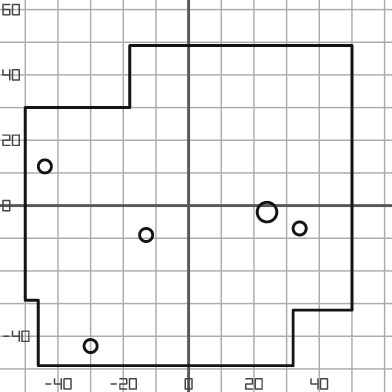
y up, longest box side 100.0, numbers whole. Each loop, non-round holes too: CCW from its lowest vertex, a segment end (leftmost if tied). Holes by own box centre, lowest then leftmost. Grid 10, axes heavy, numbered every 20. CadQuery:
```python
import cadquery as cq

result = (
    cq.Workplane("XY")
    .moveTo(-46.0, -49.0)
    .lineTo(32.0, -49.0)
    .lineTo(32.0, -32.0)
    .lineTo(50.0, -32.0)
    .lineTo(50.0, 49.0)
    .lineTo(-18.0, 49.0)
    .lineTo(-18.0, 30.0)
    .lineTo(-50.0, 30.0)
    .lineTo(-50.0, -29.0)
    .lineTo(-46.0, -29.0)
    .close()
    .moveTo(-30.0, -43.0)
    .circle(2.0)
    .moveTo(-13.0, -9.0)
    .circle(2.0)
    .moveTo(34.0, -7.0)
    .circle(2.0)
    .moveTo(24.0, -2.0)
    .circle(3.0)
    .moveTo(-44.0, 12.0)
    .circle(2.0)
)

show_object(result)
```